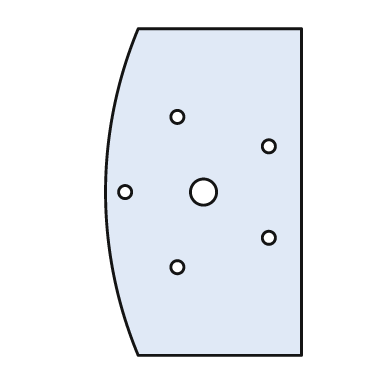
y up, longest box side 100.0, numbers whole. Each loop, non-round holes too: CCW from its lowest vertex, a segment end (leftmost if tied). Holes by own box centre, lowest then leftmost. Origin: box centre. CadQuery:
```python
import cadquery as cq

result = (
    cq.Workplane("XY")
    .moveTo(-20.0, -50.0)
    .lineTo(30.0, -50.0)
    .lineTo(30.0, 50.0)
    .lineTo(-20.0, 50.0)
    .threePointArc((-30.0, 0.0), (-20.0, -50.0))
    .close()
    .moveTo(-8.0, -23.0)
    .circle(2.0)
    .moveTo(20.0, -14.0)
    .circle(2.0)
    .moveTo(-24.0, 0.0)
    .circle(2.0)
    .moveTo(0.0, 0.0)
    .circle(4.0)
    .moveTo(20.0, 14.0)
    .circle(2.0)
    .moveTo(-8.0, 23.0)
    .circle(2.0)
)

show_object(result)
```